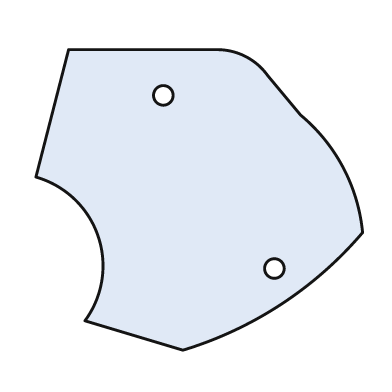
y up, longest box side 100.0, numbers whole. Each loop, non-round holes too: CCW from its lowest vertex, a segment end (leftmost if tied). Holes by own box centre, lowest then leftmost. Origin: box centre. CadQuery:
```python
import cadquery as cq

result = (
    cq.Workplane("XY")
    .moveTo(-5.0, -46.0)
    .threePointArc((25.0, -32.0), (50.0, -10.0))
    .threePointArc((44.0, 10.0), (31.0, 26.0))
    .lineTo(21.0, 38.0)
    .threePointArc((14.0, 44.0), (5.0, 46.0))
    .lineTo(-40.0, 46.0)
    .lineTo(-50.0, 7.0)
    .threePointArc((-31.0, -11.0), (-35.0, -37.0))
    .close()
    .moveTo(23.0, -21.0)
    .circle(3.0)
    .moveTo(-11.0, 32.0)
    .circle(3.0)
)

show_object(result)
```